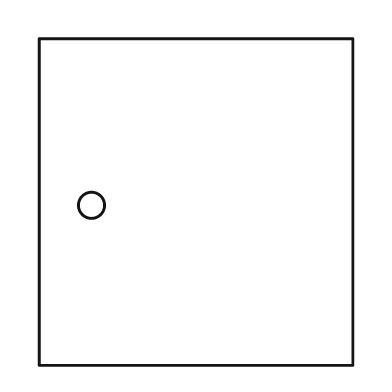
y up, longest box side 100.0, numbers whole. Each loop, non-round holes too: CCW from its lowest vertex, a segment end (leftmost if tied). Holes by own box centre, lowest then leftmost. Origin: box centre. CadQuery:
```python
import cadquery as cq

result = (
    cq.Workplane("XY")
    .moveTo(-48.0, -50.0)
    .lineTo(48.0, -50.0)
    .lineTo(48.0, 50.0)
    .lineTo(-48.0, 50.0)
    .close()
    .moveTo(-32.0, -1.0)
    .circle(4.0)
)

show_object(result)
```